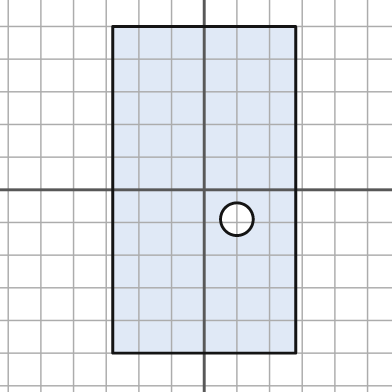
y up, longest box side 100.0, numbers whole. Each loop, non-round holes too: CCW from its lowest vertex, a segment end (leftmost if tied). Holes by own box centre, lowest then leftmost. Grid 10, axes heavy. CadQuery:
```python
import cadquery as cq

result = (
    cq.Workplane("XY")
    .moveTo(-28.0, -50.0)
    .lineTo(28.0, -50.0)
    .lineTo(28.0, 50.0)
    .lineTo(-28.0, 50.0)
    .close()
    .moveTo(10.0, -9.0)
    .circle(5.0)
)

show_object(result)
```